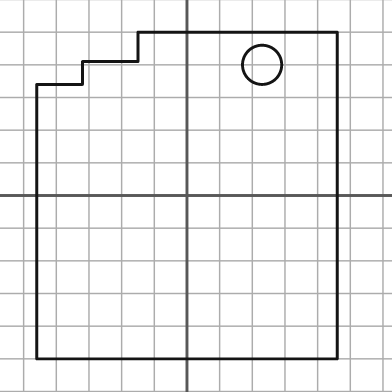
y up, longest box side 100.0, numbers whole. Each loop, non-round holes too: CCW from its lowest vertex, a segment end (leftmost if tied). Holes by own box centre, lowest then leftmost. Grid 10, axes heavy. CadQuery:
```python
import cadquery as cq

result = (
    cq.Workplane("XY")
    .moveTo(-46.0, -50.0)
    .lineTo(46.0, -50.0)
    .lineTo(46.0, 50.0)
    .lineTo(-15.0, 50.0)
    .lineTo(-15.0, 41.0)
    .lineTo(-32.0, 41.0)
    .lineTo(-32.0, 34.0)
    .lineTo(-46.0, 34.0)
    .close()
    .moveTo(23.0, 40.0)
    .circle(6.0)
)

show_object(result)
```